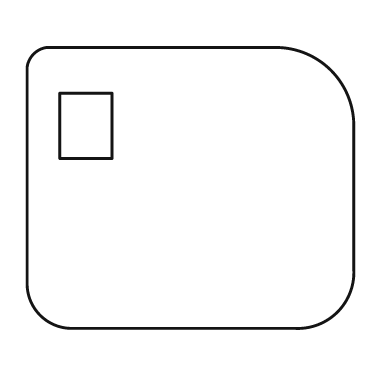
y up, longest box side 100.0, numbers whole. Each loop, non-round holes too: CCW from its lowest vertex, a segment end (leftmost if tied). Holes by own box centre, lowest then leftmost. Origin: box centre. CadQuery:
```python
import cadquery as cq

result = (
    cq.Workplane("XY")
    .moveTo(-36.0, -43.0)
    .lineTo(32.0, -43.0)
    .threePointArc((45.0, -38.0), (50.0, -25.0))
    .lineTo(50.0, 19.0)
    .threePointArc((43.0, 36.0), (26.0, 43.0))
    .lineTo(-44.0, 43.0)
    .threePointArc((-48.0, 41.0), (-50.0, 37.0))
    .lineTo(-50.0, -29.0)
    .threePointArc((-46.0, -39.0), (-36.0, -43.0))
    .close()
    .moveTo(-40.0, 9.0)
    .lineTo(-24.0, 9.0)
    .lineTo(-24.0, 29.0)
    .lineTo(-40.0, 29.0)
    .close()
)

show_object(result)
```